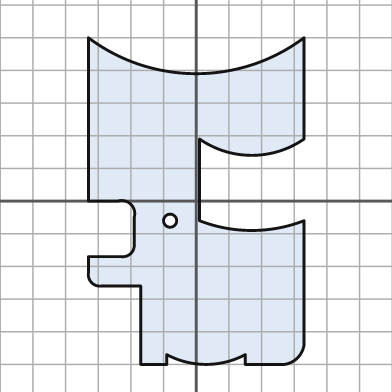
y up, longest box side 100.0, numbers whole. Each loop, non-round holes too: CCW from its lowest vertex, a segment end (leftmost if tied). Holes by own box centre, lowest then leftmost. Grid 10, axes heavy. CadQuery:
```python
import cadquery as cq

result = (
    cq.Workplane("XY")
    .moveTo(-17.0, -50.0)
    .lineTo(-9.0, -50.0)
    .lineTo(-9.0, -47.0)
    .threePointArc((3.0, -50.0), (15.0, -47.0))
    .lineTo(15.0, -50.0)
    .lineTo(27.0, -50.0)
    .threePointArc((31.0, -48.0), (33.0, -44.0))
    .lineTo(33.0, -6.0)
    .threePointArc((17.0, -9.0), (1.0, -6.0))
    .lineTo(1.0, 19.0)
    .threePointArc((17.0, 14.0), (33.0, 19.0))
    .lineTo(33.0, 50.0)
    .threePointArc((0.0, 39.0), (-33.0, 50.0))
    .lineTo(-33.0, 0.0)
    .lineTo(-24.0, 0.0)
    .threePointArc((-20.0, -1.0), (-19.0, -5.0))
    .lineTo(-19.0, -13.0)
    .threePointArc((-20.0, -16.0), (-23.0, -17.0))
    .lineTo(-33.0, -17.0)
    .lineTo(-33.0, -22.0)
    .threePointArc((-32.0, -25.0), (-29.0, -26.0))
    .lineTo(-17.0, -26.0)
    .close()
    .moveTo(-8.0, -6.0)
    .circle(2.0)
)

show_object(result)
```